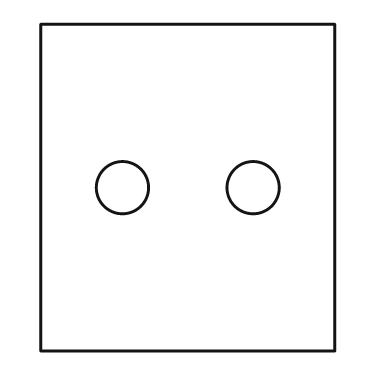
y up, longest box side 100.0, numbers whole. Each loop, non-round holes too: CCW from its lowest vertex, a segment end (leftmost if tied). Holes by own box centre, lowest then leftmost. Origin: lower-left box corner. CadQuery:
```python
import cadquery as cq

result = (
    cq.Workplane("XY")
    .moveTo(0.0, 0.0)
    .lineTo(90.0, 0.0)
    .lineTo(90.0, 100.0)
    .lineTo(0.0, 100.0)
    .close()
    .moveTo(25.0, 50.0)
    .circle(8.0)
    .moveTo(65.0, 50.0)
    .circle(8.0)
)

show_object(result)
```